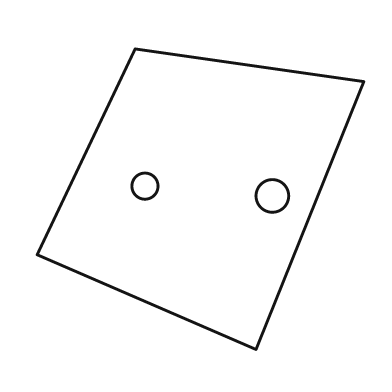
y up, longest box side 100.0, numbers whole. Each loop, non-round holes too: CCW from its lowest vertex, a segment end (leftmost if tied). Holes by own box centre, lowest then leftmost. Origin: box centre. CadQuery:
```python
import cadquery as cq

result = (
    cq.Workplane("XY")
    .moveTo(17.0, -46.0)
    .lineTo(50.0, 36.0)
    .lineTo(-20.0, 46.0)
    .lineTo(-50.0, -17.0)
    .close()
    .moveTo(22.0, 1.0)
    .circle(5.0)
    .moveTo(-17.0, 4.0)
    .circle(4.0)
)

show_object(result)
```